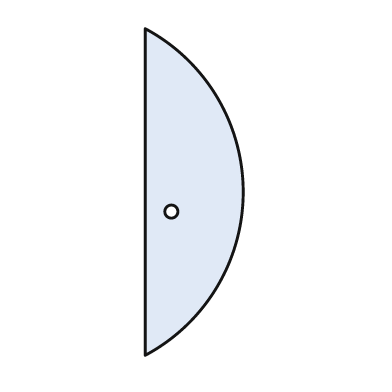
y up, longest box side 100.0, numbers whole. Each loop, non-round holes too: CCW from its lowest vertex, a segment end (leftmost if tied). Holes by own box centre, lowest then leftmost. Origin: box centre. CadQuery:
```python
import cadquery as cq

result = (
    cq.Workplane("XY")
    .moveTo(-15.0, -50.0)
    .threePointArc((15.0, 0.0), (-15.0, 50.0))
    .close()
    .moveTo(-7.0, -6.0)
    .circle(2.0)
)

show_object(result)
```